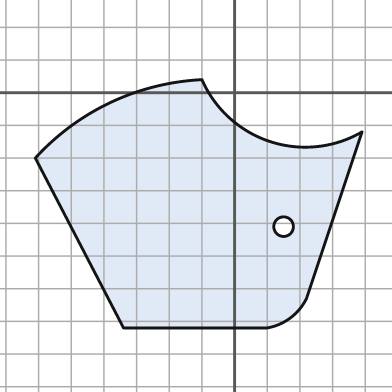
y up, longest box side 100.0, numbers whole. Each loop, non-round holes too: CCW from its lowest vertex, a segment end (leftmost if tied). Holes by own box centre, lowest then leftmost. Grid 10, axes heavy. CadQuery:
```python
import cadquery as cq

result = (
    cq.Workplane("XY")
    .moveTo(-34.0, -72.0)
    .lineTo(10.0, -72.0)
    .threePointArc((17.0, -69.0), (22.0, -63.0))
    .lineTo(39.0, -12.0)
    .threePointArc((11.0, -15.0), (-10.0, 4.0))
    .threePointArc((-38.0, -3.0), (-61.0, -20.0))
    .close()
    .moveTo(15.0, -41.0)
    .circle(3.0)
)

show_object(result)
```